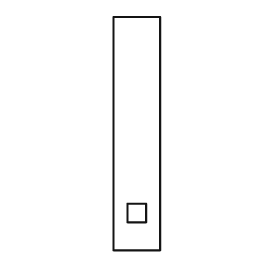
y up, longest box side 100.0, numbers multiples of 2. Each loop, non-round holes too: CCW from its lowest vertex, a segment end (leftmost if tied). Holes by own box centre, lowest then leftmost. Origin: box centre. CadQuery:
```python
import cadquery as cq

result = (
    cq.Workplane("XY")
    .moveTo(-10.0, -50.0)
    .lineTo(10.0, -50.0)
    .lineTo(10.0, 50.0)
    .lineTo(-10.0, 50.0)
    .close()
    .moveTo(-4.0, -38.0)
    .lineTo(4.0, -38.0)
    .lineTo(4.0, -30.0)
    .lineTo(-4.0, -30.0)
    .close()
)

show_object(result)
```